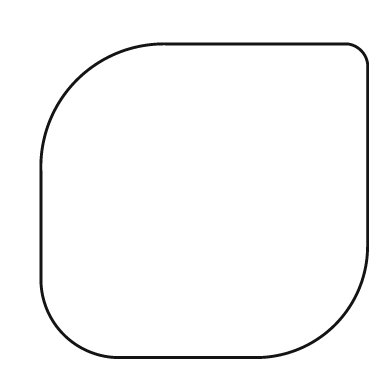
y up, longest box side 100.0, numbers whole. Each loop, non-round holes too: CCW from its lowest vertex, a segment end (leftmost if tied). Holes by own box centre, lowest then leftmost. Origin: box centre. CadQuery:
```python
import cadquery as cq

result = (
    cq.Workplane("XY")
    .moveTo(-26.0, -48.0)
    .lineTo(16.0, -48.0)
    .threePointArc((40.0, -38.0), (50.0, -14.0))
    .lineTo(50.0, 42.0)
    .threePointArc((48.0, 46.0), (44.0, 48.0))
    .lineTo(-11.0, 48.0)
    .threePointArc((-39.0, 37.0), (-50.0, 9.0))
    .lineTo(-50.0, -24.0)
    .threePointArc((-43.0, -41.0), (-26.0, -48.0))
    .close()
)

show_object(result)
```